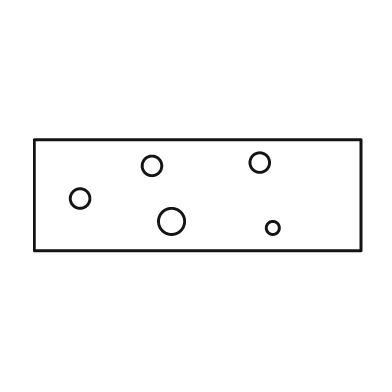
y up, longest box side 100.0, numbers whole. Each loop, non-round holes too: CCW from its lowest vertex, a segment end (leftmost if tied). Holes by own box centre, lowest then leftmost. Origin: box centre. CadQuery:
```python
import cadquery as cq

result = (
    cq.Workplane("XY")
    .moveTo(-50.0, -17.0)
    .lineTo(50.0, -17.0)
    .lineTo(50.0, 17.0)
    .lineTo(-50.0, 17.0)
    .close()
    .moveTo(23.0, -10.0)
    .circle(2.0)
    .moveTo(-8.0, -8.0)
    .circle(4.0)
    .moveTo(-36.0, -1.0)
    .circle(3.0)
    .moveTo(-14.0, 9.0)
    .circle(3.0)
    .moveTo(19.0, 10.0)
    .circle(3.0)
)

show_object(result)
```